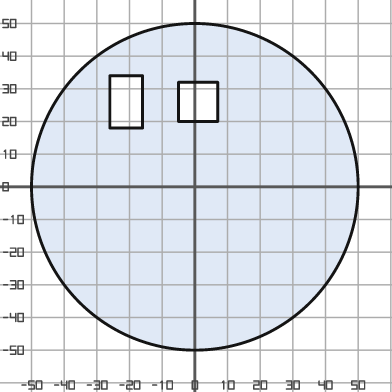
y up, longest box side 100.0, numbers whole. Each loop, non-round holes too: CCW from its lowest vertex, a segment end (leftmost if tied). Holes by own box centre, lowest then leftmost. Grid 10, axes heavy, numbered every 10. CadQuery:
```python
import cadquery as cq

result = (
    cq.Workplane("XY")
    .moveTo(0.0, 0.0)
    .circle(50.0)
    .moveTo(-26.0, 18.0)
    .lineTo(-16.0, 18.0)
    .lineTo(-16.0, 34.0)
    .lineTo(-26.0, 34.0)
    .close()
    .moveTo(-5.0, 20.0)
    .lineTo(7.0, 20.0)
    .lineTo(7.0, 32.0)
    .lineTo(-5.0, 32.0)
    .close()
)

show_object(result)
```